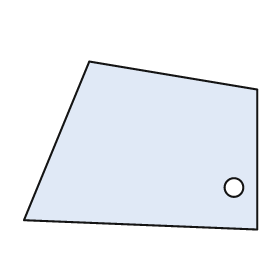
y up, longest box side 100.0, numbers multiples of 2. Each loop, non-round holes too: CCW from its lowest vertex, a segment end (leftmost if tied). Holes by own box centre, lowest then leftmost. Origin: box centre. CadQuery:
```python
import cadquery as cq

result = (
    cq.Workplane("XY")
    .moveTo(50.0, -36.0)
    .lineTo(50.0, 24.0)
    .lineTo(-22.0, 36.0)
    .lineTo(-50.0, -32.0)
    .close()
    .moveTo(40.0, -18.0)
    .circle(4.0)
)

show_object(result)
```